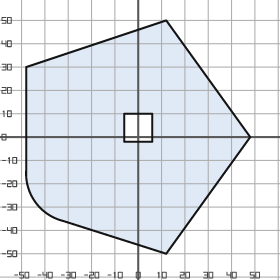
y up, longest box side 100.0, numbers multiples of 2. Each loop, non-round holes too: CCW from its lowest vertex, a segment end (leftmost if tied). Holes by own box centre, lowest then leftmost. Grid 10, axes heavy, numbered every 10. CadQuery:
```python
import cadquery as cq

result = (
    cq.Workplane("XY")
    .moveTo(12.0, -50.0)
    .lineTo(48.0, 0.0)
    .lineTo(12.0, 50.0)
    .lineTo(-48.0, 30.0)
    .lineTo(-48.0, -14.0)
    .threePointArc((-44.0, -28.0), (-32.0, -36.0))
    .close()
    .moveTo(-6.0, -2.0)
    .lineTo(6.0, -2.0)
    .lineTo(6.0, 10.0)
    .lineTo(-6.0, 10.0)
    .close()
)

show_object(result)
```